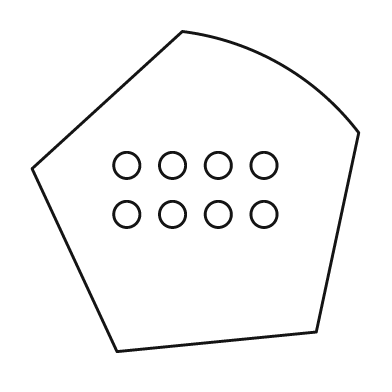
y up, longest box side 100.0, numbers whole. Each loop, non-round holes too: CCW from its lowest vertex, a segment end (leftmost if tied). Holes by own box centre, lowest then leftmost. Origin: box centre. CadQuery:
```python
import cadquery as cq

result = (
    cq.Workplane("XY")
    .moveTo(-24.0, -49.0)
    .lineTo(37.0, -43.0)
    .lineTo(50.0, 18.0)
    .threePointArc((26.0, 39.0), (-4.0, 49.0))
    .lineTo(-50.0, 7.0)
    .close()
    .moveTo(-21.0, -7.0)
    .circle(4.0)
    .moveTo(-7.0, -7.0)
    .circle(4.0)
    .moveTo(7.0, -7.0)
    .circle(4.0)
    .moveTo(21.0, -7.0)
    .circle(4.0)
    .moveTo(-21.0, 8.0)
    .circle(4.0)
    .moveTo(-7.0, 8.0)
    .circle(4.0)
    .moveTo(7.0, 8.0)
    .circle(4.0)
    .moveTo(21.0, 8.0)
    .circle(4.0)
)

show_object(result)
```